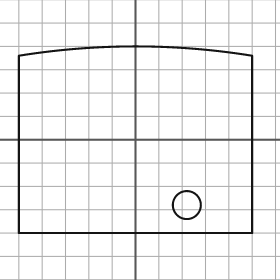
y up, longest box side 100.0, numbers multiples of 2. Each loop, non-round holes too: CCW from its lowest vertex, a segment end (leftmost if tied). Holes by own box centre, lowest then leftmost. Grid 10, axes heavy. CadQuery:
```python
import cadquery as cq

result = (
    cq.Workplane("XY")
    .moveTo(-50.0, -40.0)
    .lineTo(50.0, -40.0)
    .lineTo(50.0, 36.0)
    .threePointArc((0.0, 40.0), (-50.0, 36.0))
    .close()
    .moveTo(22.0, -28.0)
    .circle(6.0)
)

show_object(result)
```